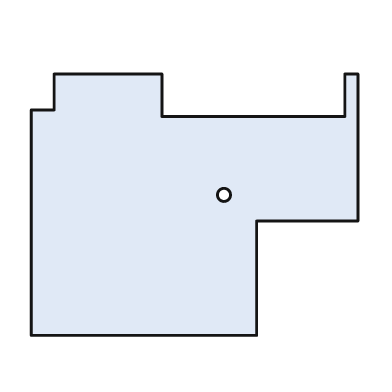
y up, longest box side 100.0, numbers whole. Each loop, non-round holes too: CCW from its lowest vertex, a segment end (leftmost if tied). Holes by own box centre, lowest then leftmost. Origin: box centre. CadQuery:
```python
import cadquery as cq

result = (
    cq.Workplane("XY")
    .moveTo(-50.0, -40.0)
    .lineTo(19.0, -40.0)
    .lineTo(19.0, -5.0)
    .lineTo(50.0, -5.0)
    .lineTo(50.0, 40.0)
    .lineTo(46.0, 40.0)
    .lineTo(46.0, 27.0)
    .lineTo(-10.0, 27.0)
    .lineTo(-10.0, 40.0)
    .lineTo(-43.0, 40.0)
    .lineTo(-43.0, 29.0)
    .lineTo(-50.0, 29.0)
    .close()
    .moveTo(9.0, 3.0)
    .circle(2.0)
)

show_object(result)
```